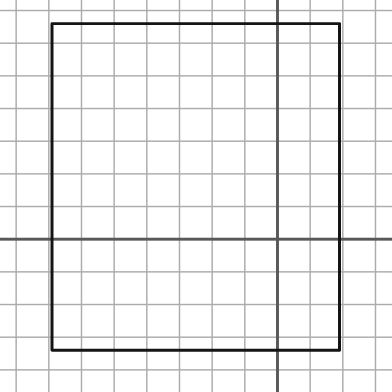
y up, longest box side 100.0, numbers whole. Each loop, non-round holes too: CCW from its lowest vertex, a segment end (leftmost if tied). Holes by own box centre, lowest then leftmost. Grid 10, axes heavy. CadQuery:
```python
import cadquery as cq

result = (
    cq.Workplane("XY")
    .moveTo(-69.0, -34.0)
    .lineTo(19.0, -34.0)
    .lineTo(19.0, 66.0)
    .lineTo(-69.0, 66.0)
    .close()
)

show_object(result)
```